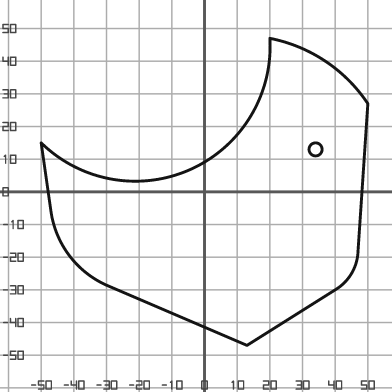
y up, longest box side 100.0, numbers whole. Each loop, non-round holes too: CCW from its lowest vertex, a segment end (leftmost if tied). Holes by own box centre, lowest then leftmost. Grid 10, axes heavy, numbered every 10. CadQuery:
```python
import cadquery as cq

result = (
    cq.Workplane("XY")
    .moveTo(13.0, -47.0)
    .lineTo(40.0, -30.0)
    .threePointArc((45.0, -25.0), (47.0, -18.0))
    .lineTo(50.0, 27.0)
    .threePointArc((37.0, 40.0), (20.0, 47.0))
    .threePointArc((-4.0, 7.0), (-50.0, 15.0))
    .lineTo(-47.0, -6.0)
    .threePointArc((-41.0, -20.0), (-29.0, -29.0))
    .close()
    .moveTo(34.0, 13.0)
    .circle(2.0)
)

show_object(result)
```